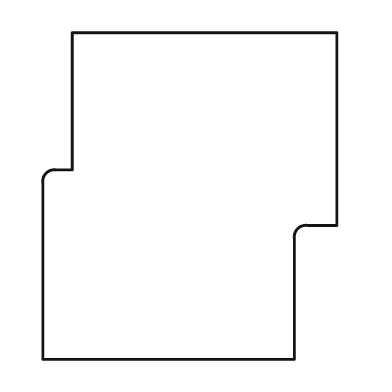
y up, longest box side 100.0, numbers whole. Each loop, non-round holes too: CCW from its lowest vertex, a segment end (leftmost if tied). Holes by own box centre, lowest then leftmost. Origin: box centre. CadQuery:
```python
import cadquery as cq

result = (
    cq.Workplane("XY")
    .moveTo(-45.0, -50.0)
    .lineTo(32.0, -50.0)
    .lineTo(32.0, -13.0)
    .threePointArc((33.0, -10.0), (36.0, -9.0))
    .lineTo(45.0, -9.0)
    .lineTo(45.0, 50.0)
    .lineTo(-36.0, 50.0)
    .lineTo(-36.0, 8.0)
    .lineTo(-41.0, 8.0)
    .threePointArc((-44.0, 7.0), (-45.0, 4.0))
    .close()
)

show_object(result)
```